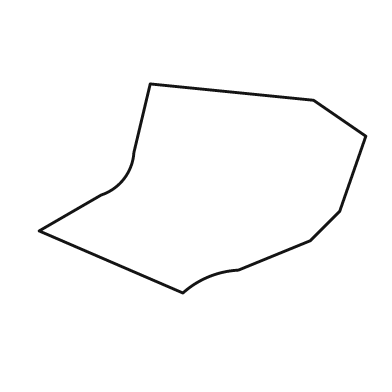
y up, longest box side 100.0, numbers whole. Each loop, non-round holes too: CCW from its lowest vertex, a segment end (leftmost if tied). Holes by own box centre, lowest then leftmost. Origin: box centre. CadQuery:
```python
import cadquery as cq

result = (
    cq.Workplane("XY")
    .moveTo(-6.0, -32.0)
    .threePointArc((2.0, -27.0), (11.0, -25.0))
    .lineTo(33.0, -16.0)
    .lineTo(42.0, -7.0)
    .lineTo(50.0, 16.0)
    .lineTo(34.0, 27.0)
    .lineTo(-16.0, 32.0)
    .lineTo(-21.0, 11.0)
    .threePointArc((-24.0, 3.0), (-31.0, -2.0))
    .lineTo(-50.0, -13.0)
    .close()
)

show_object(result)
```